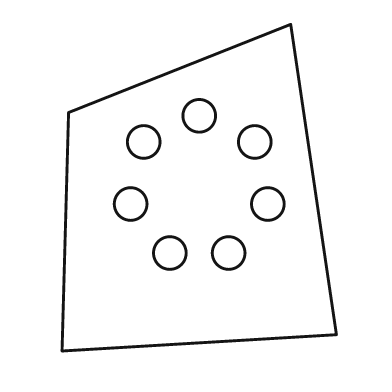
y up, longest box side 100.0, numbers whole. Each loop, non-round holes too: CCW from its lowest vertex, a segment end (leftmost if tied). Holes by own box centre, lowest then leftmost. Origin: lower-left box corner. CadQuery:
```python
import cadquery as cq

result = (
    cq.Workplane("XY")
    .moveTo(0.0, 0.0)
    .lineTo(84.0, 5.0)
    .lineTo(70.0, 100.0)
    .lineTo(2.0, 73.0)
    .close()
    .moveTo(33.0, 30.0)
    .circle(5.0)
    .moveTo(51.0, 30.0)
    .circle(5.0)
    .moveTo(21.0, 45.0)
    .circle(5.0)
    .moveTo(63.0, 45.0)
    .circle(5.0)
    .moveTo(25.0, 64.0)
    .circle(5.0)
    .moveTo(59.0, 64.0)
    .circle(5.0)
    .moveTo(42.0, 72.0)
    .circle(5.0)
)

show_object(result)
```